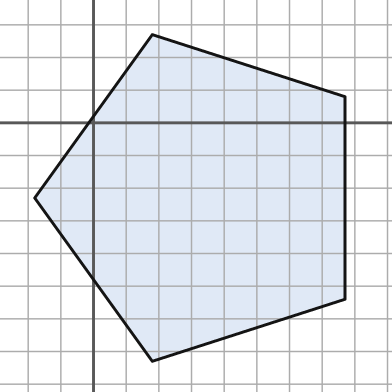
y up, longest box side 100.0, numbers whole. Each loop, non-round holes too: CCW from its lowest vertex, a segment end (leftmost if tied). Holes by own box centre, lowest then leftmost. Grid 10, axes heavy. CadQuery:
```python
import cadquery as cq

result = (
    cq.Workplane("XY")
    .moveTo(18.0, -73.0)
    .lineTo(77.0, -54.0)
    .lineTo(77.0, 8.0)
    .lineTo(18.0, 27.0)
    .lineTo(-18.0, -23.0)
    .close()
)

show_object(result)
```